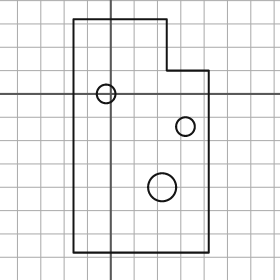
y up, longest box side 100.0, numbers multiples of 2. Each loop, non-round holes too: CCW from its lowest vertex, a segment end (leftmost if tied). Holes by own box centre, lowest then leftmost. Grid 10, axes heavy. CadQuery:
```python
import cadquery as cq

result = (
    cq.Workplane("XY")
    .moveTo(-16.0, -68.0)
    .lineTo(42.0, -68.0)
    .lineTo(42.0, 10.0)
    .lineTo(24.0, 10.0)
    .lineTo(24.0, 32.0)
    .lineTo(-16.0, 32.0)
    .close()
    .moveTo(22.0, -40.0)
    .circle(6.0)
    .moveTo(32.0, -14.0)
    .circle(4.0)
    .moveTo(-2.0, 0.0)
    .circle(4.0)
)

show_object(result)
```